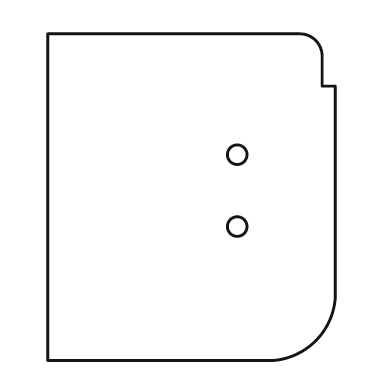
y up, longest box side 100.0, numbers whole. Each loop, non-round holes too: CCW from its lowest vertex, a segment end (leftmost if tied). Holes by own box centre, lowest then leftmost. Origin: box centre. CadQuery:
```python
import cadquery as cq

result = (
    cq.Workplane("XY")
    .moveTo(-44.0, -50.0)
    .lineTo(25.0, -50.0)
    .threePointArc((38.0, -44.0), (44.0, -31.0))
    .lineTo(44.0, 34.0)
    .lineTo(40.0, 34.0)
    .lineTo(40.0, 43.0)
    .threePointArc((38.0, 48.0), (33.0, 50.0))
    .lineTo(-44.0, 50.0)
    .close()
    .moveTo(14.0, -9.0)
    .circle(3.0)
    .moveTo(14.0, 13.0)
    .circle(3.0)
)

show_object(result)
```